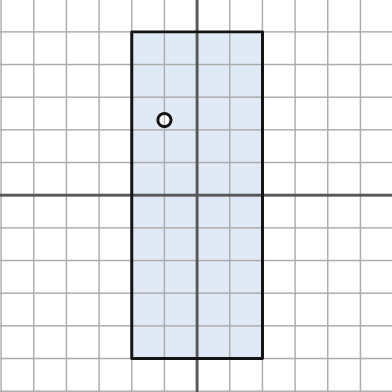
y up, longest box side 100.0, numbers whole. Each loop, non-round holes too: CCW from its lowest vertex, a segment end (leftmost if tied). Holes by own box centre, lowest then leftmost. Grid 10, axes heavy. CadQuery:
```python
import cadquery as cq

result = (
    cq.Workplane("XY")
    .moveTo(-20.0, -50.0)
    .lineTo(20.0, -50.0)
    .lineTo(20.0, 50.0)
    .lineTo(-20.0, 50.0)
    .close()
    .moveTo(-10.0, 23.0)
    .circle(2.0)
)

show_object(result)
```